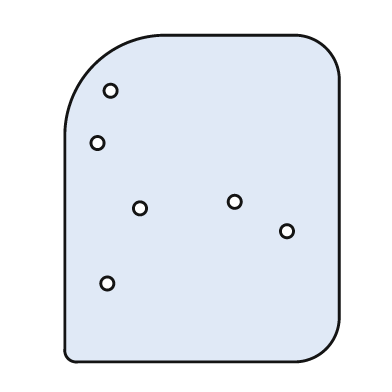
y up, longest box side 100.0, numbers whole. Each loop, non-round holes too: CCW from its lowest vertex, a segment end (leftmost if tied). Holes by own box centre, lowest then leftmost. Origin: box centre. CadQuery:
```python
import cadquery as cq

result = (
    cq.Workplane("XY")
    .moveTo(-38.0, -50.0)
    .lineTo(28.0, -50.0)
    .threePointArc((38.0, -46.0), (42.0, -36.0))
    .lineTo(42.0, 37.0)
    .threePointArc((38.0, 46.0), (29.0, 50.0))
    .lineTo(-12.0, 50.0)
    .threePointArc((-33.0, 41.0), (-42.0, 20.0))
    .lineTo(-42.0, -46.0)
    .threePointArc((-41.0, -49.0), (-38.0, -50.0))
    .close()
    .moveTo(-29.0, -26.0)
    .circle(2.0)
    .moveTo(26.0, -10.0)
    .circle(2.0)
    .moveTo(-19.0, -3.0)
    .circle(2.0)
    .moveTo(10.0, -1.0)
    .circle(2.0)
    .moveTo(-32.0, 17.0)
    .circle(2.0)
    .moveTo(-28.0, 33.0)
    .circle(2.0)
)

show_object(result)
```